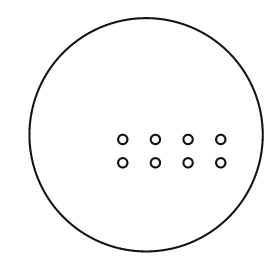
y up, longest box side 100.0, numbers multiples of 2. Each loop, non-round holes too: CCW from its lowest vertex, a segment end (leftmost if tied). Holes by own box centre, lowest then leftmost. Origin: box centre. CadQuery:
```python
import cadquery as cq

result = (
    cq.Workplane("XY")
    .moveTo(0.0, 0.0)
    .circle(50.0)
    .moveTo(-10.0, -12.0)
    .circle(2.0)
    .moveTo(4.0, -12.0)
    .circle(2.0)
    .moveTo(18.0, -12.0)
    .circle(2.0)
    .moveTo(32.0, -12.0)
    .circle(2.0)
    .moveTo(-10.0, -2.0)
    .circle(2.0)
    .moveTo(4.0, -2.0)
    .circle(2.0)
    .moveTo(18.0, -2.0)
    .circle(2.0)
    .moveTo(32.0, -2.0)
    .circle(2.0)
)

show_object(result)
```